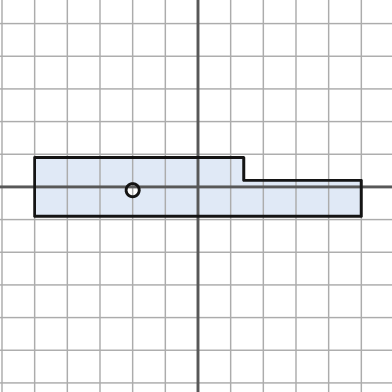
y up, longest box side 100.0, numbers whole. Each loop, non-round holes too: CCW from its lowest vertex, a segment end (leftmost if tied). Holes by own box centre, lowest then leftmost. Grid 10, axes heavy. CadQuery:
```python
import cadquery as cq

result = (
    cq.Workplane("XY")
    .moveTo(-50.0, -9.0)
    .lineTo(50.0, -9.0)
    .lineTo(50.0, 2.0)
    .lineTo(14.0, 2.0)
    .lineTo(14.0, 9.0)
    .lineTo(-50.0, 9.0)
    .close()
    .moveTo(-20.0, -1.0)
    .circle(2.0)
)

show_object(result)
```